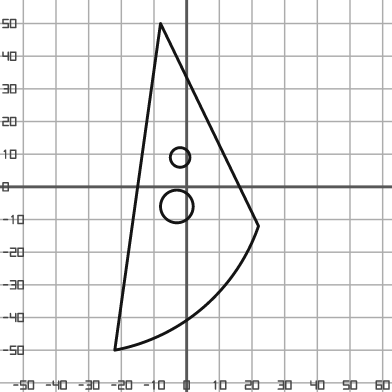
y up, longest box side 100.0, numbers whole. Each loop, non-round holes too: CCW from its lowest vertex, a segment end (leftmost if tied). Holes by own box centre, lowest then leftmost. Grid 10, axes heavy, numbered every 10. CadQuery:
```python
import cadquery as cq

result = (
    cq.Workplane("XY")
    .moveTo(-22.0, -50.0)
    .threePointArc((5.0, -37.0), (22.0, -12.0))
    .lineTo(-8.0, 50.0)
    .close()
    .moveTo(-3.0, -6.0)
    .circle(5.0)
    .moveTo(-2.0, 9.0)
    .circle(3.0)
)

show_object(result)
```